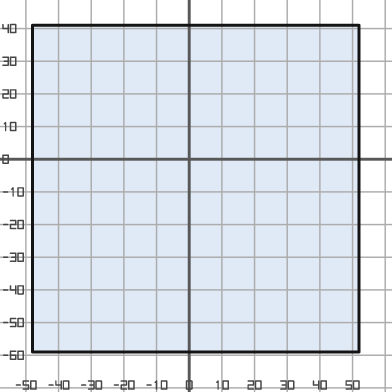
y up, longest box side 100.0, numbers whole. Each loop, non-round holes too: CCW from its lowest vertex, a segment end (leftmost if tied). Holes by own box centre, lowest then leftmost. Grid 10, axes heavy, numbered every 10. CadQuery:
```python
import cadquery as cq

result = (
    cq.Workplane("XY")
    .moveTo(-48.0, -59.0)
    .lineTo(52.0, -59.0)
    .lineTo(52.0, 41.0)
    .lineTo(-48.0, 41.0)
    .close()
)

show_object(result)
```